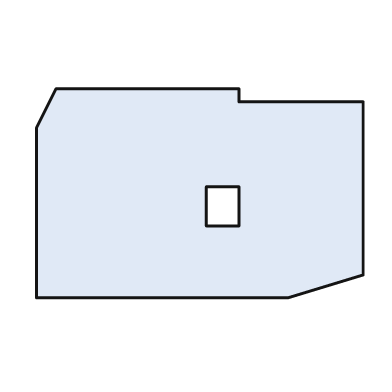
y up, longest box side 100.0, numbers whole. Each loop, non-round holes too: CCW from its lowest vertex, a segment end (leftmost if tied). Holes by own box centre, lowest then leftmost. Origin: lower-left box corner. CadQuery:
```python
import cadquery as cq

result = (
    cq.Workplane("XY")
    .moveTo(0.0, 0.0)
    .lineTo(77.0, 0.0)
    .lineTo(100.0, 7.0)
    .lineTo(100.0, 60.0)
    .lineTo(62.0, 60.0)
    .lineTo(62.0, 64.0)
    .lineTo(6.0, 64.0)
    .lineTo(0.0, 52.0)
    .close()
    .moveTo(52.0, 22.0)
    .lineTo(62.0, 22.0)
    .lineTo(62.0, 34.0)
    .lineTo(52.0, 34.0)
    .close()
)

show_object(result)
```